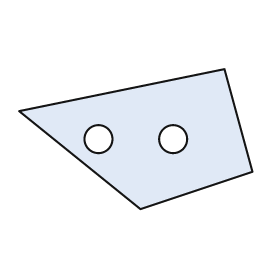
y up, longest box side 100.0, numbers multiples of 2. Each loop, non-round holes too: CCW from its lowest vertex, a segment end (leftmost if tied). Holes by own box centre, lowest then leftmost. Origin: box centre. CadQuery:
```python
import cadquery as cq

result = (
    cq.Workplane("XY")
    .moveTo(2.0, -30.0)
    .lineTo(50.0, -14.0)
    .lineTo(38.0, 30.0)
    .lineTo(-50.0, 12.0)
    .close()
    .moveTo(-16.0, 0.0)
    .circle(6.0)
    .moveTo(16.0, 0.0)
    .circle(6.0)
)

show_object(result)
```